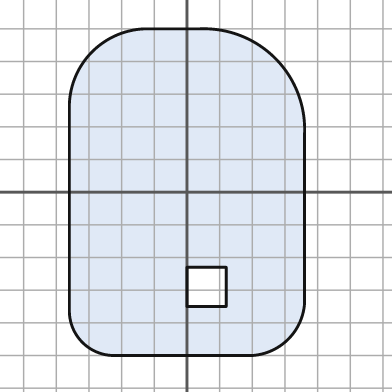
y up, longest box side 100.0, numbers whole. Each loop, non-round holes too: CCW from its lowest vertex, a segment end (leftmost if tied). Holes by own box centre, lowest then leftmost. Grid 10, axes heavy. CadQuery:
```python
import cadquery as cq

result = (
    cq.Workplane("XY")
    .moveTo(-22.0, -50.0)
    .lineTo(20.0, -50.0)
    .threePointArc((31.0, -45.0), (36.0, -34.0))
    .lineTo(36.0, 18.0)
    .threePointArc((27.0, 41.0), (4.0, 50.0))
    .lineTo(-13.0, 50.0)
    .threePointArc((-29.0, 43.0), (-36.0, 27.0))
    .lineTo(-36.0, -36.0)
    .threePointArc((-32.0, -46.0), (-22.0, -50.0))
    .close()
    .moveTo(0.0, -35.0)
    .lineTo(12.0, -35.0)
    .lineTo(12.0, -23.0)
    .lineTo(0.0, -23.0)
    .close()
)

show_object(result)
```